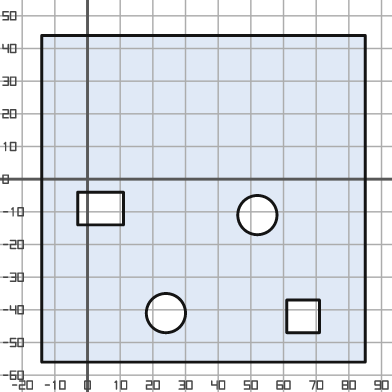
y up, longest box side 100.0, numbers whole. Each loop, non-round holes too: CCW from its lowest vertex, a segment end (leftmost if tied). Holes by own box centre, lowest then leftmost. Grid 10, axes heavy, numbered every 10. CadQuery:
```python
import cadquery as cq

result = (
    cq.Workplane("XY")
    .moveTo(-14.0, -56.0)
    .lineTo(85.0, -56.0)
    .lineTo(85.0, 44.0)
    .lineTo(-14.0, 44.0)
    .close()
    .moveTo(61.0, -47.0)
    .lineTo(71.0, -47.0)
    .lineTo(71.0, -37.0)
    .lineTo(61.0, -37.0)
    .close()
    .moveTo(24.0, -41.0)
    .circle(6.0)
    .moveTo(52.0, -11.0)
    .circle(6.0)
    .moveTo(-3.0, -14.0)
    .lineTo(11.0, -14.0)
    .lineTo(11.0, -4.0)
    .lineTo(-3.0, -4.0)
    .close()
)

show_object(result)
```